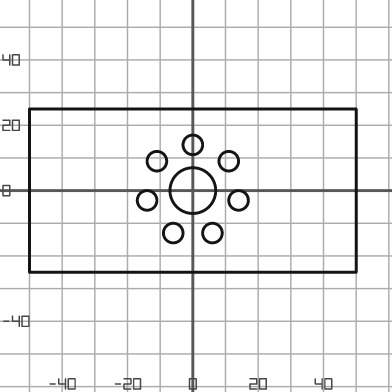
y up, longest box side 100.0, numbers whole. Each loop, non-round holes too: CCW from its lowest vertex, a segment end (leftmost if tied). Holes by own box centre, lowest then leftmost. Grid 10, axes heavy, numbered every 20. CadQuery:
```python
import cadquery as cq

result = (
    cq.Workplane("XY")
    .moveTo(-50.0, -25.0)
    .lineTo(50.0, -25.0)
    .lineTo(50.0, 25.0)
    .lineTo(-50.0, 25.0)
    .close()
    .moveTo(-6.0, -13.0)
    .circle(3.0)
    .moveTo(6.0, -13.0)
    .circle(3.0)
    .moveTo(-14.0, -3.0)
    .circle(3.0)
    .moveTo(14.0, -3.0)
    .circle(3.0)
    .moveTo(0.0, 0.0)
    .circle(7.0)
    .moveTo(-11.0, 9.0)
    .circle(3.0)
    .moveTo(11.0, 9.0)
    .circle(3.0)
    .moveTo(0.0, 14.0)
    .circle(3.0)
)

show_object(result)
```